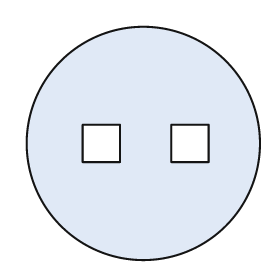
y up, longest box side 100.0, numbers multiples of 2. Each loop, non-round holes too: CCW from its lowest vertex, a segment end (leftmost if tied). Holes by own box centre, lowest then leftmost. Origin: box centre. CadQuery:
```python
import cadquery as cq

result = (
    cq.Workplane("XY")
    .moveTo(0.0, 0.0)
    .circle(50.0)
    .moveTo(-26.0, -8.0)
    .lineTo(-10.0, -8.0)
    .lineTo(-10.0, 8.0)
    .lineTo(-26.0, 8.0)
    .close()
    .moveTo(12.0, -8.0)
    .lineTo(28.0, -8.0)
    .lineTo(28.0, 8.0)
    .lineTo(12.0, 8.0)
    .close()
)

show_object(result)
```